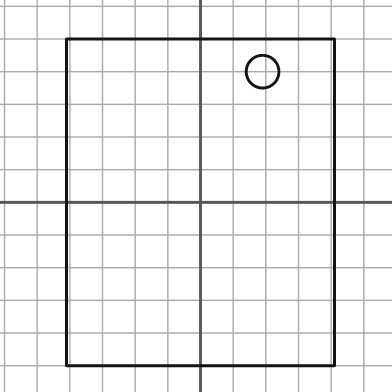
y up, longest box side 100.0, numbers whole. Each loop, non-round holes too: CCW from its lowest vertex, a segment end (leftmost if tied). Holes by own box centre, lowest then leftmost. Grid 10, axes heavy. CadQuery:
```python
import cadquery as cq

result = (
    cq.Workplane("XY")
    .moveTo(-41.0, -50.0)
    .lineTo(41.0, -50.0)
    .lineTo(41.0, 50.0)
    .lineTo(-41.0, 50.0)
    .close()
    .moveTo(19.0, 40.0)
    .circle(5.0)
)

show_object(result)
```